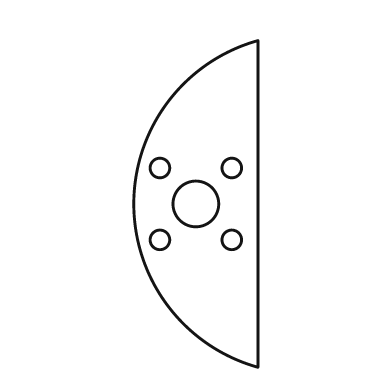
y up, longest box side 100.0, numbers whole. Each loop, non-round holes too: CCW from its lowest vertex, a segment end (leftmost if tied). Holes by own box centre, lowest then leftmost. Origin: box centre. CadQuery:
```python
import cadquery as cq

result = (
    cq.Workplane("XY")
    .moveTo(19.0, -50.0)
    .lineTo(19.0, 50.0)
    .threePointArc((-19.0, 0.0), (19.0, -50.0))
    .close()
    .moveTo(-11.0, -11.0)
    .circle(3.0)
    .moveTo(11.0, -11.0)
    .circle(3.0)
    .moveTo(0.0, 0.0)
    .circle(7.0)
    .moveTo(-11.0, 11.0)
    .circle(3.0)
    .moveTo(11.0, 11.0)
    .circle(3.0)
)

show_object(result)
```